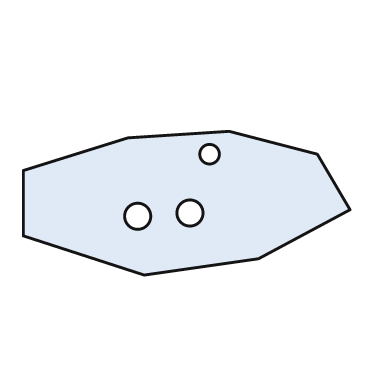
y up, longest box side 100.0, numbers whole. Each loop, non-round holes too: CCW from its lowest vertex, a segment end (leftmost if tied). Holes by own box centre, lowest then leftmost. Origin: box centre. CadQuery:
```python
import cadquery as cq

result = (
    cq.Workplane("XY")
    .moveTo(-13.0, -22.0)
    .lineTo(22.0, -17.0)
    .lineTo(50.0, -2.0)
    .lineTo(40.0, 15.0)
    .lineTo(13.0, 22.0)
    .lineTo(-18.0, 20.0)
    .lineTo(-50.0, 10.0)
    .lineTo(-50.0, -10.0)
    .close()
    .moveTo(-15.0, -4.0)
    .circle(4.0)
    .moveTo(1.0, -3.0)
    .circle(4.0)
    .moveTo(7.0, 15.0)
    .circle(3.0)
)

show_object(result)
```